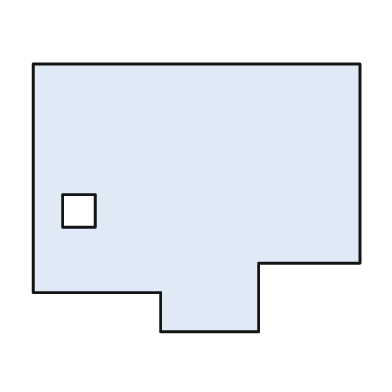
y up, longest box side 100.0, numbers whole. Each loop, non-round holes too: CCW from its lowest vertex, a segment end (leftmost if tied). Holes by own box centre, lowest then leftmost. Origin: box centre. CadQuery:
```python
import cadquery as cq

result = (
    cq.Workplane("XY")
    .moveTo(-11.0, -41.0)
    .lineTo(19.0, -41.0)
    .lineTo(19.0, -20.0)
    .lineTo(50.0, -20.0)
    .lineTo(50.0, 41.0)
    .lineTo(-50.0, 41.0)
    .lineTo(-50.0, -29.0)
    .lineTo(-11.0, -29.0)
    .close()
    .moveTo(-41.0, -9.0)
    .lineTo(-31.0, -9.0)
    .lineTo(-31.0, 1.0)
    .lineTo(-41.0, 1.0)
    .close()
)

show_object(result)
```